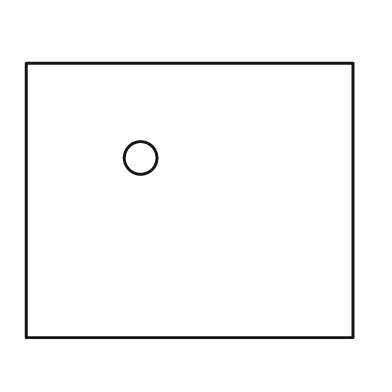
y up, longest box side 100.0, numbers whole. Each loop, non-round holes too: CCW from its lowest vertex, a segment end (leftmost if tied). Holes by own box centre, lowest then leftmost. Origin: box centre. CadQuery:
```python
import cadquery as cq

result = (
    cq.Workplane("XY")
    .moveTo(-50.0, -42.0)
    .lineTo(50.0, -42.0)
    .lineTo(50.0, 42.0)
    .lineTo(-50.0, 42.0)
    .close()
    .moveTo(-15.0, 13.0)
    .circle(5.0)
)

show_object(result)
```